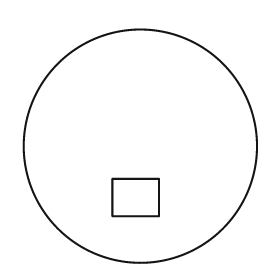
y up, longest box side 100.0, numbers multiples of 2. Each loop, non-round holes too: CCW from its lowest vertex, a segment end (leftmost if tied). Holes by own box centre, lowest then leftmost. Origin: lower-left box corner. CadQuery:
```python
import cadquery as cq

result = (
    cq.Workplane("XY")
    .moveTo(50.0, 50.0)
    .circle(50.0)
    .moveTo(38.0, 20.0)
    .lineTo(58.0, 20.0)
    .lineTo(58.0, 36.0)
    .lineTo(38.0, 36.0)
    .close()
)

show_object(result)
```